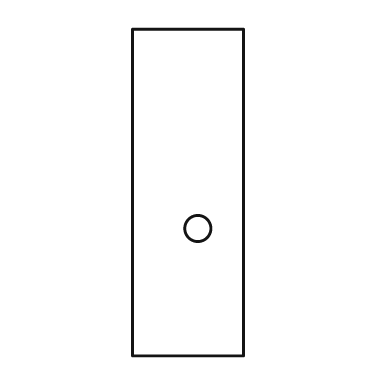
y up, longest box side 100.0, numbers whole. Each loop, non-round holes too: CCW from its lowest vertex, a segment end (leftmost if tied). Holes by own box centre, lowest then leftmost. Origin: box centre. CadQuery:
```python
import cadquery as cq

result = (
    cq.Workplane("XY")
    .moveTo(-17.0, -50.0)
    .lineTo(17.0, -50.0)
    .lineTo(17.0, 50.0)
    .lineTo(-17.0, 50.0)
    .close()
    .moveTo(3.0, -11.0)
    .circle(4.0)
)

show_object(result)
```